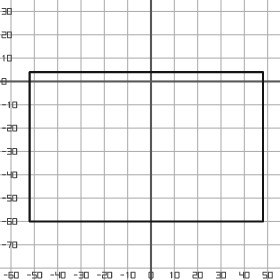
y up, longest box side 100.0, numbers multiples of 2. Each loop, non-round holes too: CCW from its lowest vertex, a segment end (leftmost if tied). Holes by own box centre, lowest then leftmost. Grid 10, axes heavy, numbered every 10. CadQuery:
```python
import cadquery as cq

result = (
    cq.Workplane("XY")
    .moveTo(-52.0, -60.0)
    .lineTo(48.0, -60.0)
    .lineTo(48.0, 4.0)
    .lineTo(-52.0, 4.0)
    .close()
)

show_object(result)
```